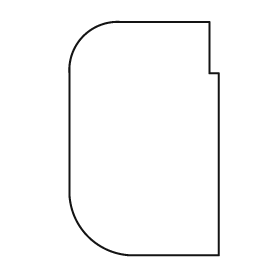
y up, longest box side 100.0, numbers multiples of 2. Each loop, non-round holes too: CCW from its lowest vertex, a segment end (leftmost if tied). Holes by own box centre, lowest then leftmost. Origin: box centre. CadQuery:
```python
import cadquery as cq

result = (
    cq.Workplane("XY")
    .moveTo(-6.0, -50.0)
    .lineTo(32.0, -50.0)
    .lineTo(32.0, 28.0)
    .lineTo(28.0, 28.0)
    .lineTo(28.0, 50.0)
    .lineTo(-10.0, 50.0)
    .threePointArc((-26.0, 44.0), (-32.0, 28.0))
    .lineTo(-32.0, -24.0)
    .threePointArc((-24.0, -42.0), (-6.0, -50.0))
    .close()
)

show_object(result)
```